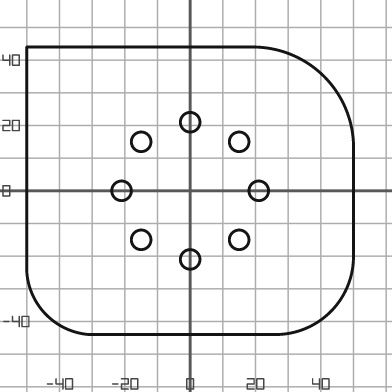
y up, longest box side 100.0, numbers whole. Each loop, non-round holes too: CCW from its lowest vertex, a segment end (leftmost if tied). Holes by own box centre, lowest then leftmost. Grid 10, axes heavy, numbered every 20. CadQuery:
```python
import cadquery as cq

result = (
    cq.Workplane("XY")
    .moveTo(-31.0, -44.0)
    .lineTo(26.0, -44.0)
    .threePointArc((43.0, -37.0), (50.0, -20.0))
    .lineTo(50.0, 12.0)
    .threePointArc((41.0, 35.0), (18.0, 44.0))
    .lineTo(-50.0, 44.0)
    .lineTo(-50.0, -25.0)
    .threePointArc((-44.0, -38.0), (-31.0, -44.0))
    .close()
    .moveTo(0.0, -21.0)
    .circle(3.0)
    .moveTo(-15.0, -15.0)
    .circle(3.0)
    .moveTo(15.0, -15.0)
    .circle(3.0)
    .moveTo(-21.0, 0.0)
    .circle(3.0)
    .moveTo(21.0, 0.0)
    .circle(3.0)
    .moveTo(-15.0, 15.0)
    .circle(3.0)
    .moveTo(15.0, 15.0)
    .circle(3.0)
    .moveTo(0.0, 21.0)
    .circle(3.0)
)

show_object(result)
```